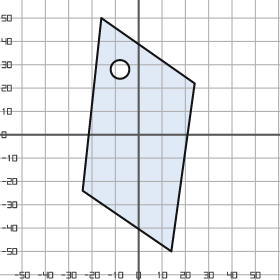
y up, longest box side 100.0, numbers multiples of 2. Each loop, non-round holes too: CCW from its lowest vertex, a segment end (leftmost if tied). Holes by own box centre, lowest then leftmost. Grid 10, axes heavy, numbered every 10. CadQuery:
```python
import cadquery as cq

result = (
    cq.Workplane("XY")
    .moveTo(14.0, -50.0)
    .lineTo(24.0, 22.0)
    .lineTo(-16.0, 50.0)
    .lineTo(-24.0, -24.0)
    .close()
    .moveTo(-8.0, 28.0)
    .circle(4.0)
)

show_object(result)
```